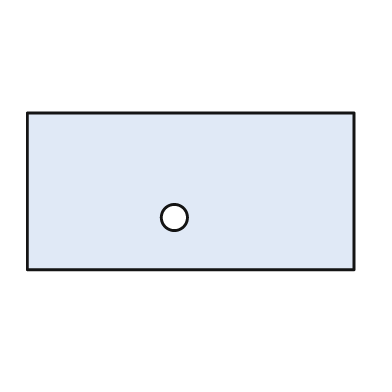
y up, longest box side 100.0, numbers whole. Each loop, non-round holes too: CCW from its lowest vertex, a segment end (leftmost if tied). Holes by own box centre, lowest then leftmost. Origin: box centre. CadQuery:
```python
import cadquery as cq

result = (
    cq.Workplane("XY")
    .moveTo(-50.0, -24.0)
    .lineTo(50.0, -24.0)
    .lineTo(50.0, 24.0)
    .lineTo(-50.0, 24.0)
    .close()
    .moveTo(-5.0, -8.0)
    .circle(4.0)
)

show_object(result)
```